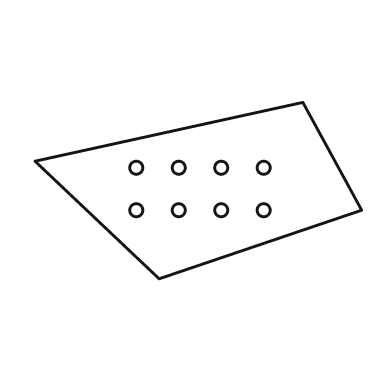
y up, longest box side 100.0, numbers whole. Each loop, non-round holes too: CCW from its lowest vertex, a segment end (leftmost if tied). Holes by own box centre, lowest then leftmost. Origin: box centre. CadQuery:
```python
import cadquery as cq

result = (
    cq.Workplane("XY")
    .moveTo(-12.0, -27.0)
    .lineTo(50.0, -6.0)
    .lineTo(32.0, 27.0)
    .lineTo(-50.0, 9.0)
    .close()
    .moveTo(-19.0, -6.0)
    .circle(2.0)
    .moveTo(-6.0, -6.0)
    .circle(2.0)
    .moveTo(7.0, -6.0)
    .circle(2.0)
    .moveTo(20.0, -6.0)
    .circle(2.0)
    .moveTo(-19.0, 7.0)
    .circle(2.0)
    .moveTo(-6.0, 7.0)
    .circle(2.0)
    .moveTo(7.0, 7.0)
    .circle(2.0)
    .moveTo(20.0, 7.0)
    .circle(2.0)
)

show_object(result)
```